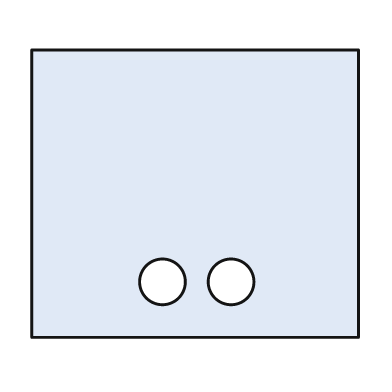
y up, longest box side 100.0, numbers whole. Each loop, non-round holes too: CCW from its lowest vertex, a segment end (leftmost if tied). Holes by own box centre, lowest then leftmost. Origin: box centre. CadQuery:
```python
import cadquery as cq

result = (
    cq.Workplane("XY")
    .moveTo(-50.0, -44.0)
    .lineTo(50.0, -44.0)
    .lineTo(50.0, 44.0)
    .lineTo(-50.0, 44.0)
    .close()
    .moveTo(-10.0, -27.0)
    .circle(7.0)
    .moveTo(11.0, -27.0)
    .circle(7.0)
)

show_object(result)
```